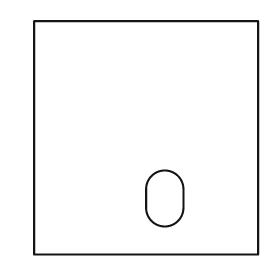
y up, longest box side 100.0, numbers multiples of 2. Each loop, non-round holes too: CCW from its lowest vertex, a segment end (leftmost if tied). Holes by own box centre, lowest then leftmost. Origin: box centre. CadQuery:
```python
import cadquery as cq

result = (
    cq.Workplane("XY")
    .moveTo(-48.0, -50.0)
    .lineTo(48.0, -50.0)
    .lineTo(48.0, 50.0)
    .lineTo(-48.0, 50.0)
    .close()
    .moveTo(0.0, -30.0)
    .threePointArc((8.0, -38.0), (16.0, -30.0))
    .lineTo(16.0, -22.0)
    .threePointArc((8.0, -14.0), (0.0, -22.0))
    .close()
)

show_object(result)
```